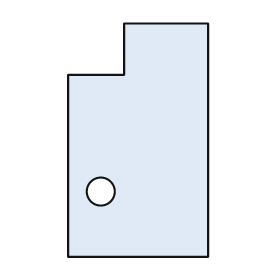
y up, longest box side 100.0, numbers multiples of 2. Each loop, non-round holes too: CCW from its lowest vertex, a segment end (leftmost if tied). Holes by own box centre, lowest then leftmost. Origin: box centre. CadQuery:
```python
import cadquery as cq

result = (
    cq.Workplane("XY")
    .moveTo(-30.0, -50.0)
    .lineTo(30.0, -50.0)
    .lineTo(30.0, 50.0)
    .lineTo(-6.0, 50.0)
    .lineTo(-6.0, 28.0)
    .lineTo(-30.0, 28.0)
    .close()
    .moveTo(-16.0, -22.0)
    .circle(6.0)
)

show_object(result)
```